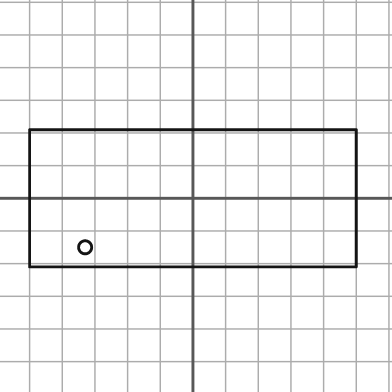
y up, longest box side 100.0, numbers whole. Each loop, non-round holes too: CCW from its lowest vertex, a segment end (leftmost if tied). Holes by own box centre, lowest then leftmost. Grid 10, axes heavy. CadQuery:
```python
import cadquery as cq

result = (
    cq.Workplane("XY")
    .moveTo(-50.0, -21.0)
    .lineTo(50.0, -21.0)
    .lineTo(50.0, 21.0)
    .lineTo(-50.0, 21.0)
    .close()
    .moveTo(-33.0, -15.0)
    .circle(2.0)
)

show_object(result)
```